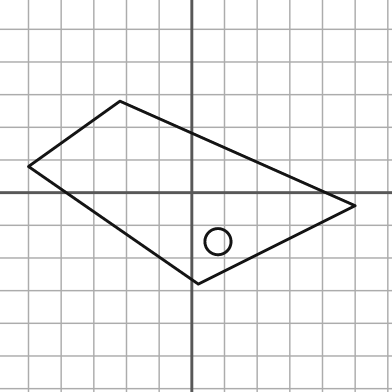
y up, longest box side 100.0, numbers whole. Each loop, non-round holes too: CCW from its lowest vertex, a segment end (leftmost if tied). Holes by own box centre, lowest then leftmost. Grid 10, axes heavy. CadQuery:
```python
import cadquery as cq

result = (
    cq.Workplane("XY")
    .moveTo(2.0, -28.0)
    .lineTo(50.0, -4.0)
    .lineTo(-22.0, 28.0)
    .lineTo(-50.0, 8.0)
    .close()
    .moveTo(8.0, -15.0)
    .circle(4.0)
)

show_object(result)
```